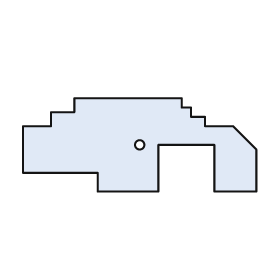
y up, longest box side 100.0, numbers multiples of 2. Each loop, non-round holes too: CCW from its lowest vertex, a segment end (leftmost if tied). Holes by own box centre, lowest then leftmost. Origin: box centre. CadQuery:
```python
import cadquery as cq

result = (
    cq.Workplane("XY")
    .moveTo(-18.0, -20.0)
    .lineTo(8.0, -20.0)
    .lineTo(8.0, 0.0)
    .lineTo(32.0, 0.0)
    .lineTo(32.0, -20.0)
    .lineTo(50.0, -20.0)
    .lineTo(50.0, -2.0)
    .lineTo(40.0, 8.0)
    .lineTo(28.0, 8.0)
    .lineTo(28.0, 12.0)
    .lineTo(22.0, 12.0)
    .lineTo(22.0, 16.0)
    .lineTo(18.0, 16.0)
    .lineTo(18.0, 20.0)
    .lineTo(-28.0, 20.0)
    .lineTo(-28.0, 14.0)
    .lineTo(-38.0, 14.0)
    .lineTo(-38.0, 8.0)
    .lineTo(-50.0, 8.0)
    .lineTo(-50.0, -12.0)
    .lineTo(-18.0, -12.0)
    .close()
    .moveTo(0.0, 0.0)
    .circle(2.0)
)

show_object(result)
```